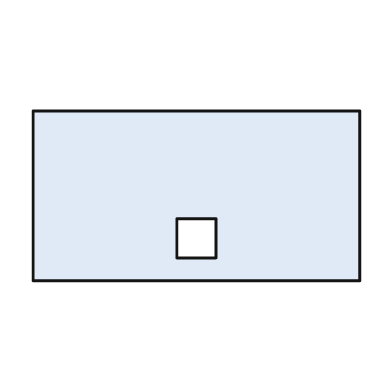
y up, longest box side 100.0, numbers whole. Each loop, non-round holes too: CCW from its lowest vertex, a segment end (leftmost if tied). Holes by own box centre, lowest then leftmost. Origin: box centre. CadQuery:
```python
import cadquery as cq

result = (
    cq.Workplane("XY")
    .moveTo(-50.0, -26.0)
    .lineTo(50.0, -26.0)
    .lineTo(50.0, 26.0)
    .lineTo(-50.0, 26.0)
    .close()
    .moveTo(-6.0, -19.0)
    .lineTo(6.0, -19.0)
    .lineTo(6.0, -7.0)
    .lineTo(-6.0, -7.0)
    .close()
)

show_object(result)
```